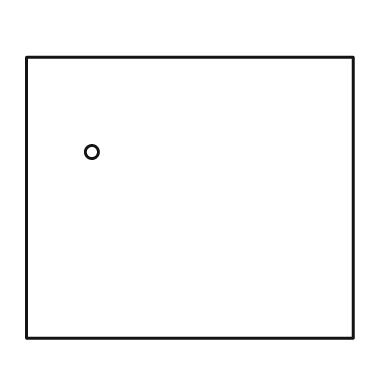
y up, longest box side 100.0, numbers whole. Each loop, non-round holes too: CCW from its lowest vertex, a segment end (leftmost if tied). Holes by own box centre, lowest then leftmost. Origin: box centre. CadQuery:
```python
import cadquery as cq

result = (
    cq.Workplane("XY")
    .moveTo(-50.0, -43.0)
    .lineTo(50.0, -43.0)
    .lineTo(50.0, 43.0)
    .lineTo(-50.0, 43.0)
    .close()
    .moveTo(-30.0, 14.0)
    .circle(2.0)
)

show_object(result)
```